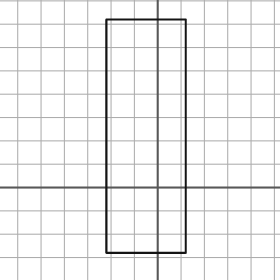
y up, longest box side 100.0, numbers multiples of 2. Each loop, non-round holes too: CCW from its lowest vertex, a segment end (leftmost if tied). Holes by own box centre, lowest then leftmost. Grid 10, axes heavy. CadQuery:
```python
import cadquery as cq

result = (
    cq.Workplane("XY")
    .moveTo(-22.0, -28.0)
    .lineTo(12.0, -28.0)
    .lineTo(12.0, 72.0)
    .lineTo(-22.0, 72.0)
    .close()
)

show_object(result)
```